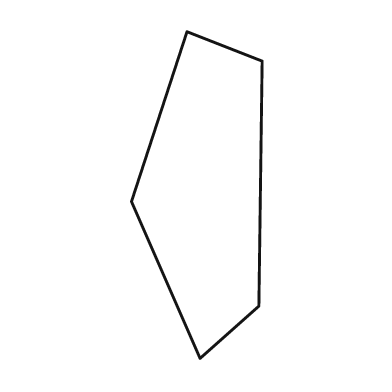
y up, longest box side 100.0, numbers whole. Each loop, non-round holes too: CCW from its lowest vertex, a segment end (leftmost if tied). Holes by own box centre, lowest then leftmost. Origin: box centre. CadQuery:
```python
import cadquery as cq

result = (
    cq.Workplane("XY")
    .moveTo(1.0, -50.0)
    .lineTo(19.0, -34.0)
    .lineTo(20.0, 41.0)
    .lineTo(-3.0, 50.0)
    .lineTo(-20.0, -2.0)
    .close()
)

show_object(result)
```